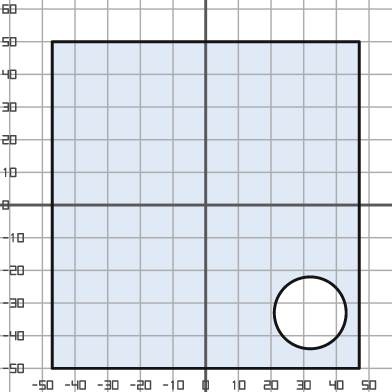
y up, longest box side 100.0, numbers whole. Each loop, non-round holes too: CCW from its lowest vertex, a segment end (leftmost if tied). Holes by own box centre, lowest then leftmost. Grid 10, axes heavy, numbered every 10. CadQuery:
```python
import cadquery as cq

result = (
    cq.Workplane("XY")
    .moveTo(-47.0, -50.0)
    .lineTo(47.0, -50.0)
    .lineTo(47.0, 50.0)
    .lineTo(-47.0, 50.0)
    .close()
    .moveTo(32.0, -33.0)
    .circle(11.0)
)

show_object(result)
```